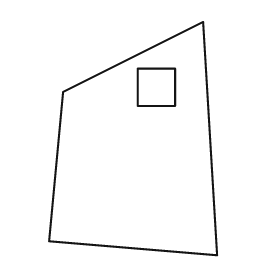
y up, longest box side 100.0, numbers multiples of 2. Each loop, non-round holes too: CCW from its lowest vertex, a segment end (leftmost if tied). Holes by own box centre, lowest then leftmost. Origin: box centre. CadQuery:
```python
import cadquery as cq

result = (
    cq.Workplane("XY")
    .moveTo(36.0, -50.0)
    .lineTo(30.0, 50.0)
    .lineTo(-30.0, 20.0)
    .lineTo(-36.0, -44.0)
    .close()
    .moveTo(2.0, 14.0)
    .lineTo(18.0, 14.0)
    .lineTo(18.0, 30.0)
    .lineTo(2.0, 30.0)
    .close()
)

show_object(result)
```